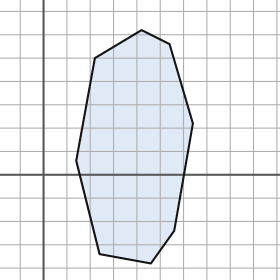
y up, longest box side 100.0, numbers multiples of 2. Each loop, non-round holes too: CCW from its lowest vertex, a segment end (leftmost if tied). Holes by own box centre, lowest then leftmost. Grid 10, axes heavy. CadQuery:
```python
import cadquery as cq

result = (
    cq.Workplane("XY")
    .moveTo(46.0, -38.0)
    .lineTo(56.0, -24.0)
    .lineTo(64.0, 22.0)
    .lineTo(54.0, 56.0)
    .lineTo(42.0, 62.0)
    .lineTo(22.0, 50.0)
    .lineTo(14.0, 6.0)
    .lineTo(24.0, -34.0)
    .close()
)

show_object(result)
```